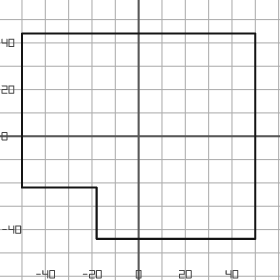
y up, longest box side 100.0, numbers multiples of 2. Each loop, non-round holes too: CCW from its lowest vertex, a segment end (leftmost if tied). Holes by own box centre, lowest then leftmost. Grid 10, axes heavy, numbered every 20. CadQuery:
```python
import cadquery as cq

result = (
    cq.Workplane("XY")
    .moveTo(-18.0, -44.0)
    .lineTo(50.0, -44.0)
    .lineTo(50.0, 44.0)
    .lineTo(-50.0, 44.0)
    .lineTo(-50.0, -22.0)
    .lineTo(-18.0, -22.0)
    .close()
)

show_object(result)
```